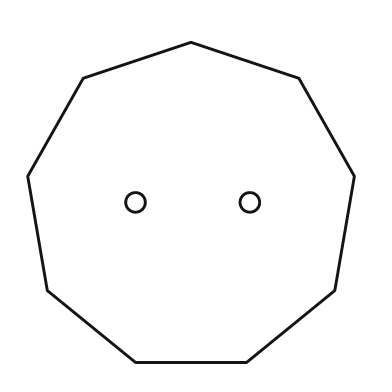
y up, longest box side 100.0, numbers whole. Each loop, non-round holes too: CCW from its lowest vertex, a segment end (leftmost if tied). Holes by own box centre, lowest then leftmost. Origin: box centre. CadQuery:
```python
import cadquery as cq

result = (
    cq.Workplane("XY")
    .moveTo(-17.0, -49.0)
    .lineTo(17.0, -49.0)
    .lineTo(44.0, -27.0)
    .lineTo(50.0, 8.0)
    .lineTo(33.0, 38.0)
    .lineTo(0.0, 49.0)
    .lineTo(-33.0, 38.0)
    .lineTo(-50.0, 8.0)
    .lineTo(-44.0, -27.0)
    .close()
    .moveTo(-17.0, 0.0)
    .circle(3.0)
    .moveTo(18.0, 0.0)
    .circle(3.0)
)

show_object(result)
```